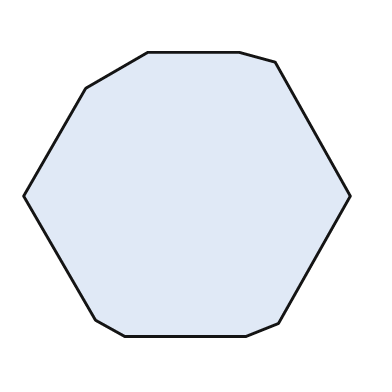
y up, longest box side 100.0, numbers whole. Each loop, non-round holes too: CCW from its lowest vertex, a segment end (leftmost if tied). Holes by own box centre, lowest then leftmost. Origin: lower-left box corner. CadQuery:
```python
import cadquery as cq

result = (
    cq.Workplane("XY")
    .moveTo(31.0, 0.0)
    .lineTo(68.0, 0.0)
    .lineTo(78.0, 4.0)
    .lineTo(100.0, 43.0)
    .lineTo(77.0, 84.0)
    .lineTo(66.0, 87.0)
    .lineTo(38.0, 87.0)
    .lineTo(19.0, 76.0)
    .lineTo(0.0, 43.0)
    .lineTo(22.0, 5.0)
    .close()
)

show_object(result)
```